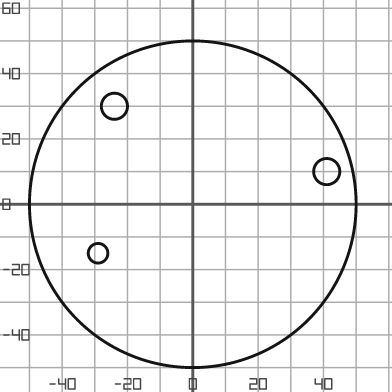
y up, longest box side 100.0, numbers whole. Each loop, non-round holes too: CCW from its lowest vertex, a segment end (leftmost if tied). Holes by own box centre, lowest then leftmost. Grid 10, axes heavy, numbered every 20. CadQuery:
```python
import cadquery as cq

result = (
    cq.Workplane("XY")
    .moveTo(0.0, 0.0)
    .circle(50.0)
    .moveTo(-29.0, -15.0)
    .circle(3.0)
    .moveTo(41.0, 10.0)
    .circle(4.0)
    .moveTo(-24.0, 30.0)
    .circle(4.0)
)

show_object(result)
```